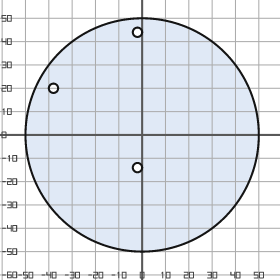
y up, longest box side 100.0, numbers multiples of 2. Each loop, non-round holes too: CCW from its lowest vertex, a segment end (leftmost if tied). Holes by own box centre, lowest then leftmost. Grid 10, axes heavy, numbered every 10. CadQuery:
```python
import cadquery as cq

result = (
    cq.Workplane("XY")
    .moveTo(0.0, 0.0)
    .circle(50.0)
    .moveTo(-2.0, -14.0)
    .circle(2.0)
    .moveTo(-38.0, 20.0)
    .circle(2.0)
    .moveTo(-2.0, 44.0)
    .circle(2.0)
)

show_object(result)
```